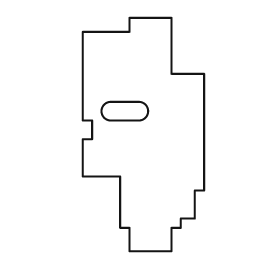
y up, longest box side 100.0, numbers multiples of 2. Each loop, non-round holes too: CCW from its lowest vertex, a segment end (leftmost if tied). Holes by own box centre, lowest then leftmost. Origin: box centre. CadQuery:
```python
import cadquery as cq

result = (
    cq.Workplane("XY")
    .moveTo(-6.0, -50.0)
    .lineTo(12.0, -50.0)
    .lineTo(12.0, -40.0)
    .lineTo(16.0, -40.0)
    .lineTo(16.0, -36.0)
    .lineTo(22.0, -36.0)
    .lineTo(22.0, -24.0)
    .lineTo(26.0, -24.0)
    .lineTo(26.0, 26.0)
    .lineTo(12.0, 26.0)
    .lineTo(12.0, 50.0)
    .lineTo(-6.0, 50.0)
    .lineTo(-6.0, 44.0)
    .lineTo(-26.0, 44.0)
    .lineTo(-26.0, 6.0)
    .lineTo(-22.0, 6.0)
    .lineTo(-22.0, -2.0)
    .lineTo(-26.0, -2.0)
    .lineTo(-26.0, -18.0)
    .lineTo(-10.0, -18.0)
    .lineTo(-10.0, -40.0)
    .lineTo(-6.0, -40.0)
    .close()
    .moveTo(-14.0, 6.0)
    .lineTo(-2.0, 6.0)
    .threePointArc((2.0, 10.0), (-2.0, 14.0))
    .lineTo(-14.0, 14.0)
    .threePointArc((-18.0, 10.0), (-14.0, 6.0))
    .close()
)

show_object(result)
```